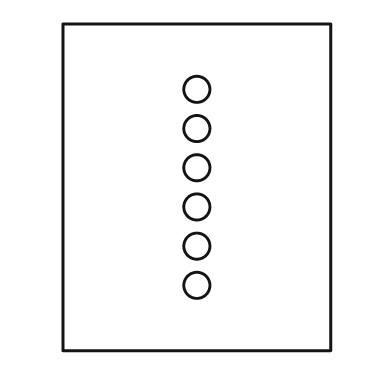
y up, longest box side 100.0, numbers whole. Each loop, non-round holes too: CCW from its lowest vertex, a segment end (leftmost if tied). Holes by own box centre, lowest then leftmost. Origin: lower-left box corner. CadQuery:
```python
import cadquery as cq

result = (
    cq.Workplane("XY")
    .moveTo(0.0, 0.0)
    .lineTo(82.0, 0.0)
    .lineTo(82.0, 100.0)
    .lineTo(0.0, 100.0)
    .close()
    .moveTo(41.0, 20.0)
    .circle(4.0)
    .moveTo(41.0, 32.0)
    .circle(4.0)
    .moveTo(41.0, 44.0)
    .circle(4.0)
    .moveTo(41.0, 56.0)
    .circle(4.0)
    .moveTo(41.0, 68.0)
    .circle(4.0)
    .moveTo(41.0, 80.0)
    .circle(4.0)
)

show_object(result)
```